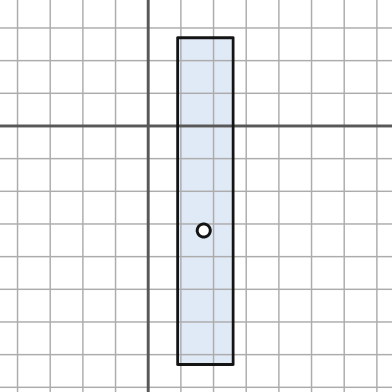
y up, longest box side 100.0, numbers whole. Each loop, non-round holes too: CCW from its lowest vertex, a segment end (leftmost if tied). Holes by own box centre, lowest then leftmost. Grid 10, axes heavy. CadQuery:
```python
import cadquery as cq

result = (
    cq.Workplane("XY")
    .moveTo(9.0, -73.0)
    .lineTo(26.0, -73.0)
    .lineTo(26.0, 27.0)
    .lineTo(9.0, 27.0)
    .close()
    .moveTo(17.0, -32.0)
    .circle(2.0)
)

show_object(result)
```